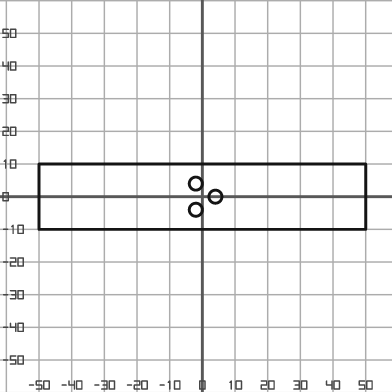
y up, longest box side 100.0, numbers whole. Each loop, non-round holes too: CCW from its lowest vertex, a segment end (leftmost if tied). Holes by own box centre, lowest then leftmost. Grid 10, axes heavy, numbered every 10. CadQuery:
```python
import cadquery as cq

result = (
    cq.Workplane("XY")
    .moveTo(-50.0, -10.0)
    .lineTo(50.0, -10.0)
    .lineTo(50.0, 10.0)
    .lineTo(-50.0, 10.0)
    .close()
    .moveTo(-2.0, -4.0)
    .circle(2.0)
    .moveTo(4.0, 0.0)
    .circle(2.0)
    .moveTo(-2.0, 4.0)
    .circle(2.0)
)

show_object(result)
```